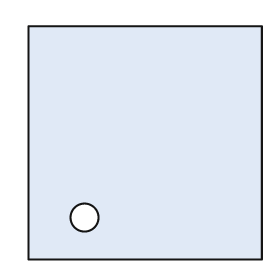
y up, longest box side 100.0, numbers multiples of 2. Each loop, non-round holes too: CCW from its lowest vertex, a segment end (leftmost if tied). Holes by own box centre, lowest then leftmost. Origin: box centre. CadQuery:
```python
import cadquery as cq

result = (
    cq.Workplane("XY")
    .moveTo(-50.0, -50.0)
    .lineTo(50.0, -50.0)
    .lineTo(50.0, 50.0)
    .lineTo(-50.0, 50.0)
    .close()
    .moveTo(-26.0, -32.0)
    .circle(6.0)
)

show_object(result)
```